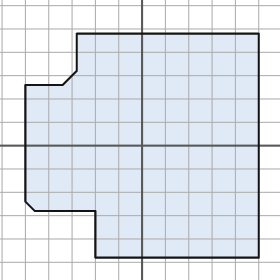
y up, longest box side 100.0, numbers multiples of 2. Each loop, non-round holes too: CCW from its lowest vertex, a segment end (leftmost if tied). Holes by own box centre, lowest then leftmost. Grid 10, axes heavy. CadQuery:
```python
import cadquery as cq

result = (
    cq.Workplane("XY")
    .moveTo(-20.0, -48.0)
    .lineTo(50.0, -48.0)
    .lineTo(50.0, 48.0)
    .lineTo(-28.0, 48.0)
    .lineTo(-28.0, 32.0)
    .lineTo(-34.0, 26.0)
    .lineTo(-50.0, 26.0)
    .lineTo(-50.0, -24.0)
    .lineTo(-46.0, -28.0)
    .lineTo(-20.0, -28.0)
    .close()
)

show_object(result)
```